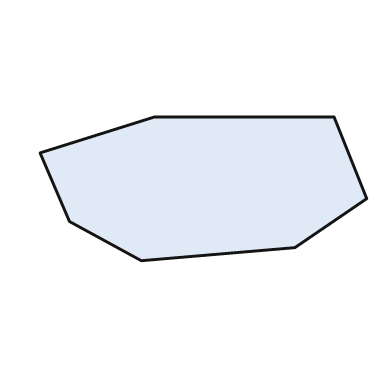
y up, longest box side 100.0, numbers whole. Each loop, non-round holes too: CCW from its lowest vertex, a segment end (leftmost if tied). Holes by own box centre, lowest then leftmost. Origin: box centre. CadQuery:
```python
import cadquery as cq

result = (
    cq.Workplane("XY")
    .moveTo(-19.0, -22.0)
    .lineTo(28.0, -18.0)
    .lineTo(50.0, -3.0)
    .lineTo(40.0, 22.0)
    .lineTo(-15.0, 22.0)
    .lineTo(-50.0, 11.0)
    .lineTo(-41.0, -10.0)
    .close()
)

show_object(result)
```